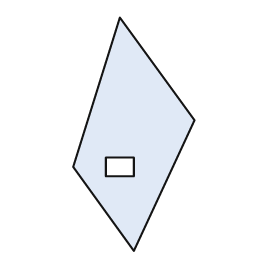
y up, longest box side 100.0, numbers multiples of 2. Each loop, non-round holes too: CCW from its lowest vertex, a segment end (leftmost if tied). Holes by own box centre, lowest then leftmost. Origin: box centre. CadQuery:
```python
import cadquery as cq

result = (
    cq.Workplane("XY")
    .moveTo(0.0, -50.0)
    .lineTo(26.0, 6.0)
    .lineTo(-6.0, 50.0)
    .lineTo(-26.0, -14.0)
    .close()
    .moveTo(-12.0, -18.0)
    .lineTo(0.0, -18.0)
    .lineTo(0.0, -10.0)
    .lineTo(-12.0, -10.0)
    .close()
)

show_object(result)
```